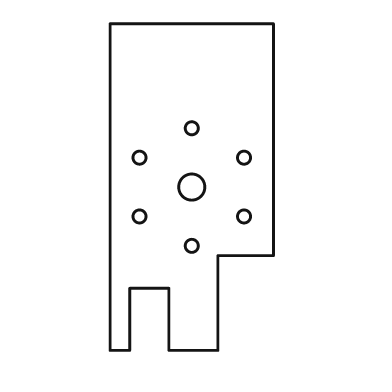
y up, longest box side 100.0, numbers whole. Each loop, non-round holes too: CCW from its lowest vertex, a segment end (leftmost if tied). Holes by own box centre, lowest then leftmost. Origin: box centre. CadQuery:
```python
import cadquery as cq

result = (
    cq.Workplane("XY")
    .moveTo(-25.0, -50.0)
    .lineTo(-19.0, -50.0)
    .lineTo(-19.0, -31.0)
    .lineTo(-7.0, -31.0)
    .lineTo(-7.0, -50.0)
    .lineTo(8.0, -50.0)
    .lineTo(8.0, -21.0)
    .lineTo(25.0, -21.0)
    .lineTo(25.0, 50.0)
    .lineTo(-25.0, 50.0)
    .close()
    .moveTo(0.0, -18.0)
    .circle(2.0)
    .moveTo(-16.0, -9.0)
    .circle(2.0)
    .moveTo(16.0, -9.0)
    .circle(2.0)
    .moveTo(0.0, 0.0)
    .circle(4.0)
    .moveTo(-16.0, 9.0)
    .circle(2.0)
    .moveTo(16.0, 9.0)
    .circle(2.0)
    .moveTo(0.0, 18.0)
    .circle(2.0)
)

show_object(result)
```